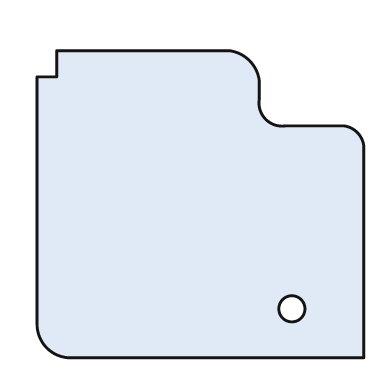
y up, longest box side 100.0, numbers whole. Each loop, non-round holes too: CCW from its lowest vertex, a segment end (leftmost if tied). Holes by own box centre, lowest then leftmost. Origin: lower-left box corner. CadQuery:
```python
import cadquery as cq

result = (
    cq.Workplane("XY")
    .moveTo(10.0, 0.0)
    .lineTo(100.0, 0.0)
    .lineTo(100.0, 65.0)
    .threePointArc((98.0, 69.0), (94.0, 71.0))
    .lineTo(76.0, 71.0)
    .threePointArc((70.0, 73.0), (68.0, 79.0))
    .lineTo(68.0, 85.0)
    .threePointArc((65.0, 91.0), (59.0, 94.0))
    .lineTo(6.0, 94.0)
    .lineTo(6.0, 86.0)
    .lineTo(0.0, 86.0)
    .lineTo(0.0, 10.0)
    .threePointArc((3.0, 3.0), (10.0, 0.0))
    .close()
    .moveTo(78.0, 15.0)
    .circle(4.0)
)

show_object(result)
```